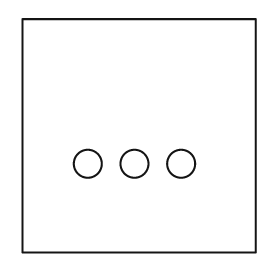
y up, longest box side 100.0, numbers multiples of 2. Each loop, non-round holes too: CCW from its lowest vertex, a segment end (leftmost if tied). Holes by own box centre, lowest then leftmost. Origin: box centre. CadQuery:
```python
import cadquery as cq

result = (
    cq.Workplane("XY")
    .moveTo(-50.0, -50.0)
    .lineTo(50.0, -50.0)
    .lineTo(50.0, 50.0)
    .lineTo(-50.0, 50.0)
    .close()
    .moveTo(-22.0, -12.0)
    .circle(6.0)
    .moveTo(-2.0, -12.0)
    .circle(6.0)
    .moveTo(18.0, -12.0)
    .circle(6.0)
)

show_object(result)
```